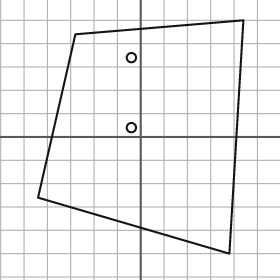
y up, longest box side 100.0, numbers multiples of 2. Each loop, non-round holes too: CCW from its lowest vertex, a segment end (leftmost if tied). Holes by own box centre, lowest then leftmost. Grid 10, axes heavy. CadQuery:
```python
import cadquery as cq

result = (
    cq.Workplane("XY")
    .moveTo(38.0, -50.0)
    .lineTo(44.0, 50.0)
    .lineTo(-28.0, 44.0)
    .lineTo(-44.0, -26.0)
    .close()
    .moveTo(-4.0, 4.0)
    .circle(2.0)
    .moveTo(-4.0, 34.0)
    .circle(2.0)
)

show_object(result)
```